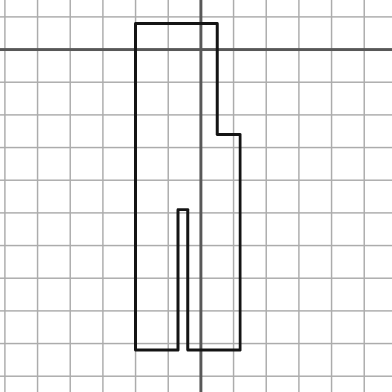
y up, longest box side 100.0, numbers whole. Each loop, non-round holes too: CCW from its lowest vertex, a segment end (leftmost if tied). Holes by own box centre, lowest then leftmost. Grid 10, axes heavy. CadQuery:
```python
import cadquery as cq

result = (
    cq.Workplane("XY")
    .moveTo(-20.0, -92.0)
    .lineTo(-7.0, -92.0)
    .lineTo(-7.0, -49.0)
    .lineTo(-4.0, -49.0)
    .lineTo(-4.0, -92.0)
    .lineTo(12.0, -92.0)
    .lineTo(12.0, -26.0)
    .lineTo(5.0, -26.0)
    .lineTo(5.0, 8.0)
    .lineTo(-20.0, 8.0)
    .close()
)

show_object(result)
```